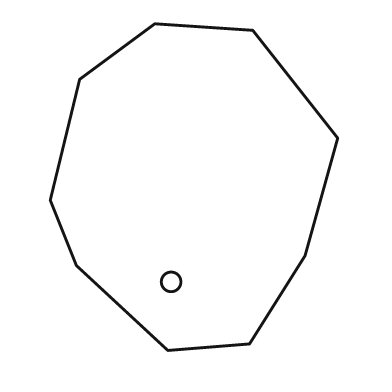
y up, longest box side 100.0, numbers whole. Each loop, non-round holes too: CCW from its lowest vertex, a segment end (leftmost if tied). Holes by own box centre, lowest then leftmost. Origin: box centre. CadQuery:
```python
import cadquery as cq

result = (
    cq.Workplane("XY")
    .moveTo(-8.0, -50.0)
    .lineTo(17.0, -48.0)
    .lineTo(34.0, -21.0)
    .lineTo(44.0, 15.0)
    .lineTo(18.0, 48.0)
    .lineTo(-12.0, 50.0)
    .lineTo(-35.0, 33.0)
    .lineTo(-44.0, -4.0)
    .lineTo(-36.0, -24.0)
    .close()
    .moveTo(-7.0, -29.0)
    .circle(3.0)
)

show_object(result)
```